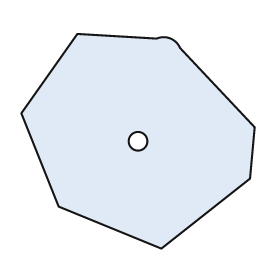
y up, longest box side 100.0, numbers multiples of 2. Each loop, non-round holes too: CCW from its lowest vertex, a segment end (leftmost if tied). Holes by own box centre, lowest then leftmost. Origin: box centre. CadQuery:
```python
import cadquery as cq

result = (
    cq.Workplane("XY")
    .moveTo(10.0, -46.0)
    .lineTo(48.0, -16.0)
    .lineTo(50.0, 6.0)
    .lineTo(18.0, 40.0)
    .threePointArc((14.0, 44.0), (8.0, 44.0))
    .lineTo(-26.0, 46.0)
    .lineTo(-50.0, 12.0)
    .lineTo(-34.0, -28.0)
    .close()
    .moveTo(0.0, 0.0)
    .circle(4.0)
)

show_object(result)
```